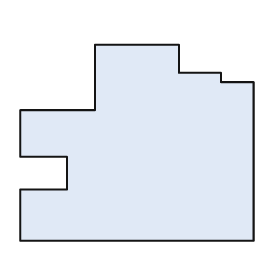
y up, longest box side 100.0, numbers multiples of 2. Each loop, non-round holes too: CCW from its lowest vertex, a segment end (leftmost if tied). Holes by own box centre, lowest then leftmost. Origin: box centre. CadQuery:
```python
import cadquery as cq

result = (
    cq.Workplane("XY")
    .moveTo(-50.0, -42.0)
    .lineTo(50.0, -42.0)
    .lineTo(50.0, 26.0)
    .lineTo(36.0, 26.0)
    .lineTo(36.0, 30.0)
    .lineTo(18.0, 30.0)
    .lineTo(18.0, 42.0)
    .lineTo(-18.0, 42.0)
    .lineTo(-18.0, 14.0)
    .lineTo(-50.0, 14.0)
    .lineTo(-50.0, -6.0)
    .lineTo(-30.0, -6.0)
    .lineTo(-30.0, -20.0)
    .lineTo(-50.0, -20.0)
    .close()
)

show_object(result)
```